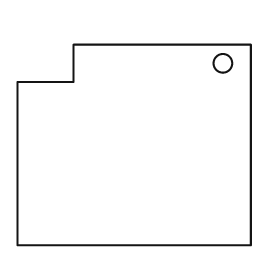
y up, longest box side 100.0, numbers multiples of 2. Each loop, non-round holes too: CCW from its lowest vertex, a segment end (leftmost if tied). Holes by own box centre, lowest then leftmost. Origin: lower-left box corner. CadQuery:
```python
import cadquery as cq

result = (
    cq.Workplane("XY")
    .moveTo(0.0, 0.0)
    .lineTo(100.0, 0.0)
    .lineTo(100.0, 86.0)
    .lineTo(24.0, 86.0)
    .lineTo(24.0, 70.0)
    .lineTo(0.0, 70.0)
    .close()
    .moveTo(88.0, 78.0)
    .circle(4.0)
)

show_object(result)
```